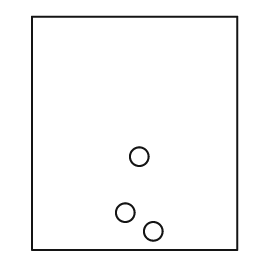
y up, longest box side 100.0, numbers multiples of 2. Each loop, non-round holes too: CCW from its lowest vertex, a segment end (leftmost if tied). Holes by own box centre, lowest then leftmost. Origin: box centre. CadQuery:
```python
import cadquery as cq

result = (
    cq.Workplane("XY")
    .moveTo(-44.0, -50.0)
    .lineTo(44.0, -50.0)
    .lineTo(44.0, 50.0)
    .lineTo(-44.0, 50.0)
    .close()
    .moveTo(8.0, -42.0)
    .circle(4.0)
    .moveTo(-4.0, -34.0)
    .circle(4.0)
    .moveTo(2.0, -10.0)
    .circle(4.0)
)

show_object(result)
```